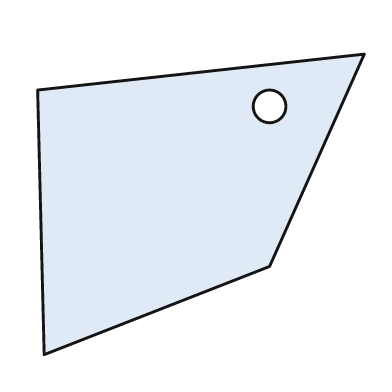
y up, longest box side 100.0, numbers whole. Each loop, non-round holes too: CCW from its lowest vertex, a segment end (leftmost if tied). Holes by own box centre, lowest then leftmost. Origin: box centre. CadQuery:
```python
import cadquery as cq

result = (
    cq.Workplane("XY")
    .moveTo(-48.0, -46.0)
    .lineTo(21.0, -19.0)
    .lineTo(50.0, 46.0)
    .lineTo(-50.0, 35.0)
    .close()
    .moveTo(21.0, 30.0)
    .circle(5.0)
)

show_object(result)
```